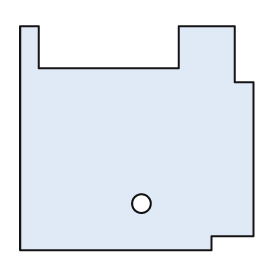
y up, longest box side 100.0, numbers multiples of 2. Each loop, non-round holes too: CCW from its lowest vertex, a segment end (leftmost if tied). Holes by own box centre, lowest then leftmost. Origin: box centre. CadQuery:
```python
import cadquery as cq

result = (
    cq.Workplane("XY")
    .moveTo(-50.0, -48.0)
    .lineTo(32.0, -48.0)
    .lineTo(32.0, -42.0)
    .lineTo(50.0, -42.0)
    .lineTo(50.0, 24.0)
    .lineTo(42.0, 24.0)
    .lineTo(42.0, 48.0)
    .lineTo(18.0, 48.0)
    .lineTo(18.0, 30.0)
    .lineTo(-42.0, 30.0)
    .lineTo(-42.0, 48.0)
    .lineTo(-50.0, 48.0)
    .close()
    .moveTo(2.0, -28.0)
    .circle(4.0)
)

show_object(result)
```